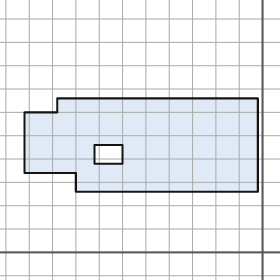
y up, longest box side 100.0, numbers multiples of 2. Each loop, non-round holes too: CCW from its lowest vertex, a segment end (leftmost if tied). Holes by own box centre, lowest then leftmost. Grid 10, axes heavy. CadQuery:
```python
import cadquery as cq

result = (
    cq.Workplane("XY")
    .moveTo(-80.0, 26.0)
    .lineTo(-2.0, 26.0)
    .lineTo(-2.0, 66.0)
    .lineTo(-88.0, 66.0)
    .lineTo(-88.0, 60.0)
    .lineTo(-102.0, 60.0)
    .lineTo(-102.0, 34.0)
    .lineTo(-80.0, 34.0)
    .close()
    .moveTo(-72.0, 38.0)
    .lineTo(-60.0, 38.0)
    .lineTo(-60.0, 46.0)
    .lineTo(-72.0, 46.0)
    .close()
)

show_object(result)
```